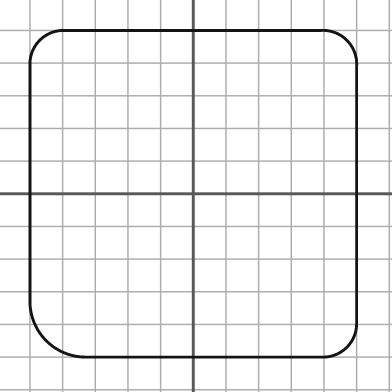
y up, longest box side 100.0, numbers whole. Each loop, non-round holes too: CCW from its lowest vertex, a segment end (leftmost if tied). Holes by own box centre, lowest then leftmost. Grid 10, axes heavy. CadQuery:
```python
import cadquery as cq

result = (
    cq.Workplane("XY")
    .moveTo(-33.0, -50.0)
    .lineTo(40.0, -50.0)
    .threePointArc((47.0, -47.0), (50.0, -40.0))
    .lineTo(50.0, 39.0)
    .threePointArc((47.0, 47.0), (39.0, 50.0))
    .lineTo(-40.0, 50.0)
    .threePointArc((-47.0, 47.0), (-50.0, 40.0))
    .lineTo(-50.0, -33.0)
    .threePointArc((-45.0, -45.0), (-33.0, -50.0))
    .close()
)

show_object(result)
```